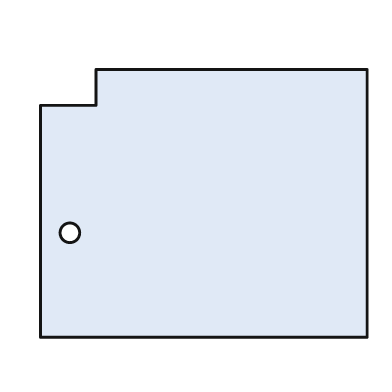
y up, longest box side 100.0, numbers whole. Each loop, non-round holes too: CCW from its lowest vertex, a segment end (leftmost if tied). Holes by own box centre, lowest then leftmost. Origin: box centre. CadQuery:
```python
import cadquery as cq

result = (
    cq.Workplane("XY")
    .moveTo(-50.0, -41.0)
    .lineTo(50.0, -41.0)
    .lineTo(50.0, 41.0)
    .lineTo(-33.0, 41.0)
    .lineTo(-33.0, 30.0)
    .lineTo(-50.0, 30.0)
    .close()
    .moveTo(-41.0, -9.0)
    .circle(3.0)
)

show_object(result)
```